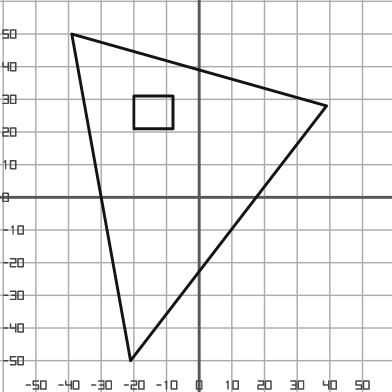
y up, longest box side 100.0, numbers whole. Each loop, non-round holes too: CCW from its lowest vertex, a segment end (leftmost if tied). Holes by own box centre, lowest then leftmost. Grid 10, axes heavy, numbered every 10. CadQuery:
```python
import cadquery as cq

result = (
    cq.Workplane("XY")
    .moveTo(-21.0, -50.0)
    .lineTo(39.0, 28.0)
    .lineTo(-39.0, 50.0)
    .close()
    .moveTo(-20.0, 21.0)
    .lineTo(-8.0, 21.0)
    .lineTo(-8.0, 31.0)
    .lineTo(-20.0, 31.0)
    .close()
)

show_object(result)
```